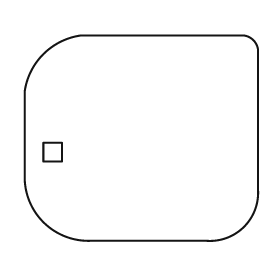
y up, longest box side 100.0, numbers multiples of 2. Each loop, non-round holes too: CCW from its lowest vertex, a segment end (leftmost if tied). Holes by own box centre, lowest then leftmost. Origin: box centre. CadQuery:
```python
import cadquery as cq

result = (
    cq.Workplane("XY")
    .moveTo(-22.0, -44.0)
    .lineTo(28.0, -44.0)
    .threePointArc((44.0, -38.0), (50.0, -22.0))
    .lineTo(50.0, 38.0)
    .threePointArc((48.0, 42.0), (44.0, 44.0))
    .lineTo(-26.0, 44.0)
    .threePointArc((-42.0, 36.0), (-50.0, 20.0))
    .lineTo(-50.0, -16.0)
    .threePointArc((-42.0, -36.0), (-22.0, -44.0))
    .close()
    .moveTo(-42.0, -10.0)
    .lineTo(-34.0, -10.0)
    .lineTo(-34.0, -2.0)
    .lineTo(-42.0, -2.0)
    .close()
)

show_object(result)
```